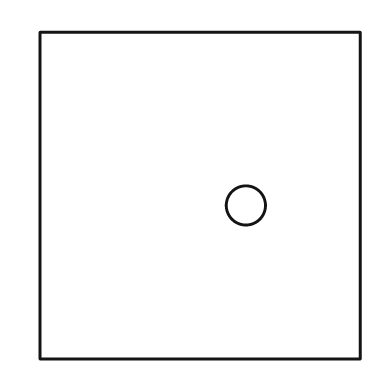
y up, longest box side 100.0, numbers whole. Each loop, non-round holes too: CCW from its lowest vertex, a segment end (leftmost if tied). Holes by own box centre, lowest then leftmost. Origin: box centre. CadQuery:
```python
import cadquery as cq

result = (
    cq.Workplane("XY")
    .moveTo(-49.0, -50.0)
    .lineTo(49.0, -50.0)
    .lineTo(49.0, 50.0)
    .lineTo(-49.0, 50.0)
    .close()
    .moveTo(14.0, -3.0)
    .circle(6.0)
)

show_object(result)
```